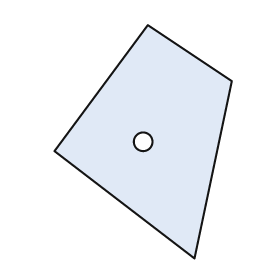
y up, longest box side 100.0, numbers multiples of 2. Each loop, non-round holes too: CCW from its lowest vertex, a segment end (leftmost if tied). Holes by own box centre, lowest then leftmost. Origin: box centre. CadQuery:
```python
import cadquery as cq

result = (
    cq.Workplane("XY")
    .moveTo(22.0, -50.0)
    .lineTo(38.0, 26.0)
    .lineTo(2.0, 50.0)
    .lineTo(-38.0, -4.0)
    .close()
    .moveTo(0.0, 0.0)
    .circle(4.0)
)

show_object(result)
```